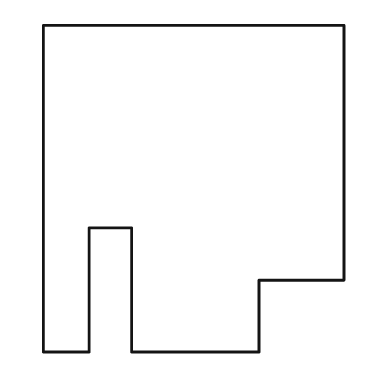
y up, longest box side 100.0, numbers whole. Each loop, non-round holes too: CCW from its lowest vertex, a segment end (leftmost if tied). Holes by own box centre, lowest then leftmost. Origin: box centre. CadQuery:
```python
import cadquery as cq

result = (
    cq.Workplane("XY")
    .moveTo(-46.0, -50.0)
    .lineTo(-32.0, -50.0)
    .lineTo(-32.0, -12.0)
    .lineTo(-19.0, -12.0)
    .lineTo(-19.0, -50.0)
    .lineTo(20.0, -50.0)
    .lineTo(20.0, -28.0)
    .lineTo(46.0, -28.0)
    .lineTo(46.0, 50.0)
    .lineTo(-46.0, 50.0)
    .close()
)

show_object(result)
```